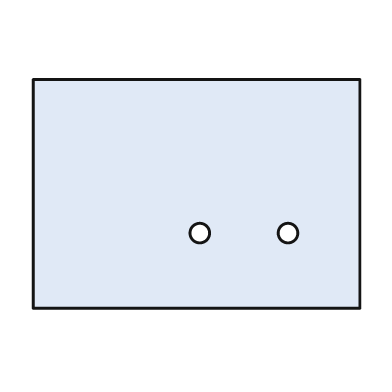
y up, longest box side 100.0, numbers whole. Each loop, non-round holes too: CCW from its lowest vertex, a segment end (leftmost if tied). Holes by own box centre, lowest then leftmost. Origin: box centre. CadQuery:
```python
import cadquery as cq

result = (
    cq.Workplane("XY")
    .moveTo(-50.0, -35.0)
    .lineTo(50.0, -35.0)
    .lineTo(50.0, 35.0)
    .lineTo(-50.0, 35.0)
    .close()
    .moveTo(1.0, -12.0)
    .circle(3.0)
    .moveTo(28.0, -12.0)
    .circle(3.0)
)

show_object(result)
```